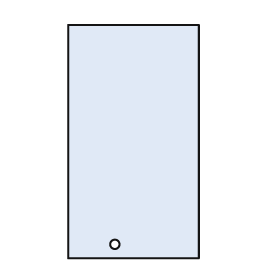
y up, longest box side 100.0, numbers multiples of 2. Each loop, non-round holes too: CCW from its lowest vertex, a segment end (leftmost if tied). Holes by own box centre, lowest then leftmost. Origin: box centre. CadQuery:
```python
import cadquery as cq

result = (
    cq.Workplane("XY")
    .moveTo(-28.0, -50.0)
    .lineTo(28.0, -50.0)
    .lineTo(28.0, 50.0)
    .lineTo(-28.0, 50.0)
    .close()
    .moveTo(-8.0, -44.0)
    .circle(2.0)
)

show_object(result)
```